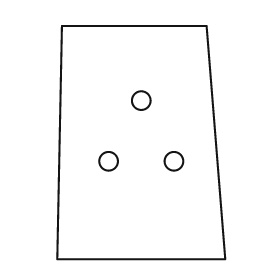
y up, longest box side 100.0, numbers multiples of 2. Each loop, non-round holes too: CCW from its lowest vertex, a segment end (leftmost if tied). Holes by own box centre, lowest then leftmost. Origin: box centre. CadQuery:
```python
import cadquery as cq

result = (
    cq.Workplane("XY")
    .moveTo(-36.0, -50.0)
    .lineTo(36.0, -50.0)
    .lineTo(28.0, 50.0)
    .lineTo(-34.0, 50.0)
    .close()
    .moveTo(-14.0, -8.0)
    .circle(4.0)
    .moveTo(14.0, -8.0)
    .circle(4.0)
    .moveTo(0.0, 18.0)
    .circle(4.0)
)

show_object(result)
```